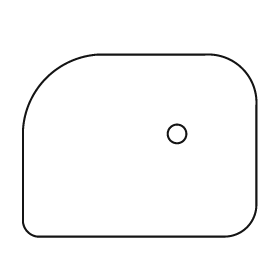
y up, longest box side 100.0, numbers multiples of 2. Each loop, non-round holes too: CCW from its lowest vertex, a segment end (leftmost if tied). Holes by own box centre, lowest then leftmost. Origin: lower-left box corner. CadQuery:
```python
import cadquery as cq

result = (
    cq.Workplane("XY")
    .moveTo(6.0, 0.0)
    .lineTo(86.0, 0.0)
    .threePointArc((96.0, 4.0), (100.0, 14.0))
    .lineTo(100.0, 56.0)
    .threePointArc((94.0, 72.0), (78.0, 78.0))
    .lineTo(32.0, 78.0)
    .threePointArc((10.0, 68.0), (0.0, 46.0))
    .lineTo(0.0, 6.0)
    .threePointArc((2.0, 2.0), (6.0, 0.0))
    .close()
    .moveTo(66.0, 44.0)
    .circle(4.0)
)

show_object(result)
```